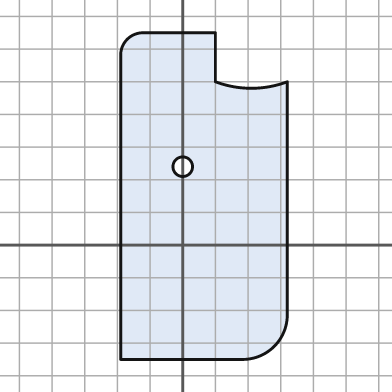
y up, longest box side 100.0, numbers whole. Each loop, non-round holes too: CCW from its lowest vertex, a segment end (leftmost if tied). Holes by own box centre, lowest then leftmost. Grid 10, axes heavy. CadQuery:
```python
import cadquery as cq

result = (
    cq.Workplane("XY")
    .moveTo(-19.0, -35.0)
    .lineTo(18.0, -35.0)
    .threePointArc((28.0, -31.0), (32.0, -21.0))
    .lineTo(32.0, 50.0)
    .threePointArc((21.0, 48.0), (10.0, 50.0))
    .lineTo(10.0, 65.0)
    .lineTo(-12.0, 65.0)
    .threePointArc((-17.0, 63.0), (-19.0, 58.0))
    .close()
    .moveTo(0.0, 24.0)
    .circle(3.0)
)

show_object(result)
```